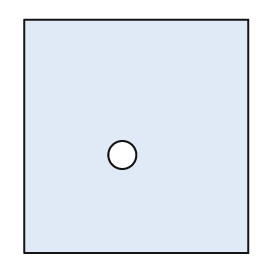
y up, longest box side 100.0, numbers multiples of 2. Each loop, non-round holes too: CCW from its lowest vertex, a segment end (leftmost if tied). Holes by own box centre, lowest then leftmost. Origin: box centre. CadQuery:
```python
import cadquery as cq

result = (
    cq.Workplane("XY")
    .moveTo(-48.0, -50.0)
    .lineTo(48.0, -50.0)
    .lineTo(48.0, 50.0)
    .lineTo(-48.0, 50.0)
    .close()
    .moveTo(-6.0, -8.0)
    .circle(6.0)
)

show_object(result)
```